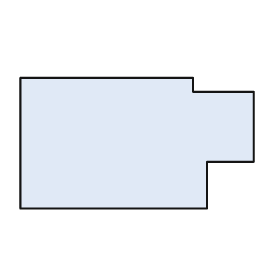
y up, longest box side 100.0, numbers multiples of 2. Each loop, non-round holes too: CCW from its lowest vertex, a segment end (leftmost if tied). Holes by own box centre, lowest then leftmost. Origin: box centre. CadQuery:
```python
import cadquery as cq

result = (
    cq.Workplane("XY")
    .moveTo(-50.0, -28.0)
    .lineTo(30.0, -28.0)
    .lineTo(30.0, -8.0)
    .lineTo(50.0, -8.0)
    .lineTo(50.0, 22.0)
    .lineTo(24.0, 22.0)
    .lineTo(24.0, 28.0)
    .lineTo(-50.0, 28.0)
    .close()
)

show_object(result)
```